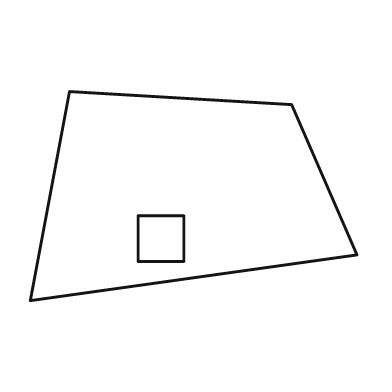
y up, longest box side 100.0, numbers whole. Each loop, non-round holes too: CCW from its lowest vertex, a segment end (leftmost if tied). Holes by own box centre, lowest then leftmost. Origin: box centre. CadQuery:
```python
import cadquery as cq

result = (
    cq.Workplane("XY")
    .moveTo(-50.0, -32.0)
    .lineTo(50.0, -18.0)
    .lineTo(30.0, 28.0)
    .lineTo(-38.0, 32.0)
    .close()
    .moveTo(-17.0, -20.0)
    .lineTo(-3.0, -20.0)
    .lineTo(-3.0, -6.0)
    .lineTo(-17.0, -6.0)
    .close()
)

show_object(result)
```